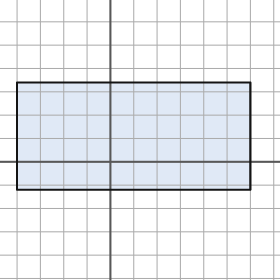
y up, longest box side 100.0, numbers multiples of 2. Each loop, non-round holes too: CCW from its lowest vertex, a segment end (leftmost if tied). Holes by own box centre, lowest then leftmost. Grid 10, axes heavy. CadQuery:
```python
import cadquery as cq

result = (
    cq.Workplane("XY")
    .moveTo(-40.0, -12.0)
    .lineTo(60.0, -12.0)
    .lineTo(60.0, 34.0)
    .lineTo(-40.0, 34.0)
    .close()
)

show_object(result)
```